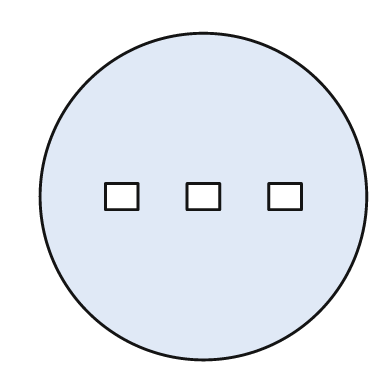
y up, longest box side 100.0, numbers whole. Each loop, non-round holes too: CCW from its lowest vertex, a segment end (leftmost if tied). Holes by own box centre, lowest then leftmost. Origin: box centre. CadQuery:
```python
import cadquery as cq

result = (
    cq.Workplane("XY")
    .moveTo(0.0, 0.0)
    .circle(50.0)
    .moveTo(-30.0, -4.0)
    .lineTo(-20.0, -4.0)
    .lineTo(-20.0, 4.0)
    .lineTo(-30.0, 4.0)
    .close()
    .moveTo(-5.0, -4.0)
    .lineTo(5.0, -4.0)
    .lineTo(5.0, 4.0)
    .lineTo(-5.0, 4.0)
    .close()
    .moveTo(20.0, -4.0)
    .lineTo(30.0, -4.0)
    .lineTo(30.0, 4.0)
    .lineTo(20.0, 4.0)
    .close()
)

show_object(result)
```